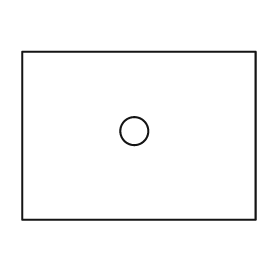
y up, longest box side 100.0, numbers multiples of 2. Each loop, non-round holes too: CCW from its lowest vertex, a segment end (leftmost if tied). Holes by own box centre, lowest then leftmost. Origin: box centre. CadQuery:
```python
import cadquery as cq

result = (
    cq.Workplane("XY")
    .moveTo(-50.0, -36.0)
    .lineTo(50.0, -36.0)
    .lineTo(50.0, 36.0)
    .lineTo(-50.0, 36.0)
    .close()
    .moveTo(-2.0, 2.0)
    .circle(6.0)
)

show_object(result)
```